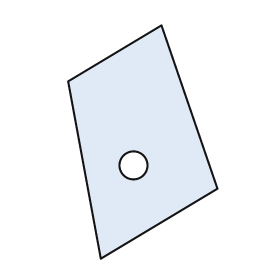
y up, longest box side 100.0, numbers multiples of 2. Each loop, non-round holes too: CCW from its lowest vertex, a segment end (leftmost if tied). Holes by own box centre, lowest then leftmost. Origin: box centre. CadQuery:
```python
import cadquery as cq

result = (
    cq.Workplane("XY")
    .moveTo(-18.0, -50.0)
    .lineTo(32.0, -20.0)
    .lineTo(8.0, 50.0)
    .lineTo(-32.0, 26.0)
    .close()
    .moveTo(-4.0, -10.0)
    .circle(6.0)
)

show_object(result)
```